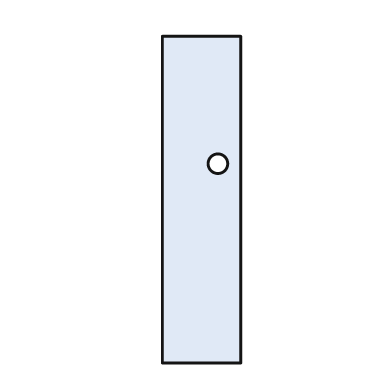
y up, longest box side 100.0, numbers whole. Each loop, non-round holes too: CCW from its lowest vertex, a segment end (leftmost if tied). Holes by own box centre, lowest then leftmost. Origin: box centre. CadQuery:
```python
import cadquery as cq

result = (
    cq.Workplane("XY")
    .moveTo(-12.0, -50.0)
    .lineTo(12.0, -50.0)
    .lineTo(12.0, 50.0)
    .lineTo(-12.0, 50.0)
    .close()
    .moveTo(5.0, 11.0)
    .circle(3.0)
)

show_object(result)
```